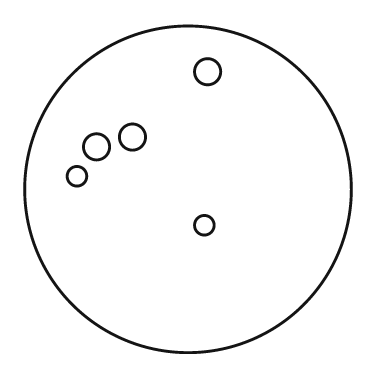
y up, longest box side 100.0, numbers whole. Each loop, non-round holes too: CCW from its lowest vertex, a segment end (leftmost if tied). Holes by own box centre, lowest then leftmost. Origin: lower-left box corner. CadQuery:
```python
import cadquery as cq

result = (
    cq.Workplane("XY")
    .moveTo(50.0, 50.0)
    .circle(50.0)
    .moveTo(55.0, 39.0)
    .circle(3.0)
    .moveTo(16.0, 54.0)
    .circle(3.0)
    .moveTo(22.0, 63.0)
    .circle(4.0)
    .moveTo(33.0, 66.0)
    .circle(4.0)
    .moveTo(56.0, 86.0)
    .circle(4.0)
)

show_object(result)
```